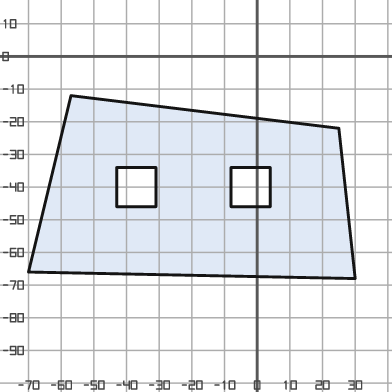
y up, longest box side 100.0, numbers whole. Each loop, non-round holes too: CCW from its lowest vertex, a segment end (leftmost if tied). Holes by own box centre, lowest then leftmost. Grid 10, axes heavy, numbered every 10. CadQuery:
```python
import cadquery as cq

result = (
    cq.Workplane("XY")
    .moveTo(30.0, -68.0)
    .lineTo(25.0, -22.0)
    .lineTo(-57.0, -12.0)
    .lineTo(-70.0, -66.0)
    .close()
    .moveTo(-43.0, -46.0)
    .lineTo(-31.0, -46.0)
    .lineTo(-31.0, -34.0)
    .lineTo(-43.0, -34.0)
    .close()
    .moveTo(-8.0, -46.0)
    .lineTo(4.0, -46.0)
    .lineTo(4.0, -34.0)
    .lineTo(-8.0, -34.0)
    .close()
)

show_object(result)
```